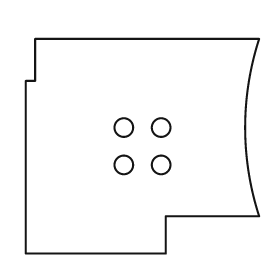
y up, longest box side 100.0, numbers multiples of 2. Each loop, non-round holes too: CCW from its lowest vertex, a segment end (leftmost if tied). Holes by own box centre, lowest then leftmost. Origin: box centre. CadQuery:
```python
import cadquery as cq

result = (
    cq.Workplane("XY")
    .moveTo(-50.0, -46.0)
    .lineTo(10.0, -46.0)
    .lineTo(10.0, -30.0)
    .lineTo(50.0, -30.0)
    .threePointArc((44.0, 8.0), (50.0, 46.0))
    .lineTo(-46.0, 46.0)
    .lineTo(-46.0, 28.0)
    .lineTo(-50.0, 28.0)
    .close()
    .moveTo(-8.0, -8.0)
    .circle(4.0)
    .moveTo(8.0, -8.0)
    .circle(4.0)
    .moveTo(-8.0, 8.0)
    .circle(4.0)
    .moveTo(8.0, 8.0)
    .circle(4.0)
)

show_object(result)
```